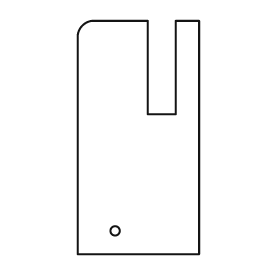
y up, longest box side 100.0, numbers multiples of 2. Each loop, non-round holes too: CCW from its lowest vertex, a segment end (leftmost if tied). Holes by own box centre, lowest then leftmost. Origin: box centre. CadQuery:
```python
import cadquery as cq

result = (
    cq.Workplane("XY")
    .moveTo(-26.0, -50.0)
    .lineTo(26.0, -50.0)
    .lineTo(26.0, 50.0)
    .lineTo(16.0, 50.0)
    .lineTo(16.0, 10.0)
    .lineTo(4.0, 10.0)
    .lineTo(4.0, 50.0)
    .lineTo(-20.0, 50.0)
    .threePointArc((-24.0, 48.0), (-26.0, 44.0))
    .close()
    .moveTo(-10.0, -40.0)
    .circle(2.0)
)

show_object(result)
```